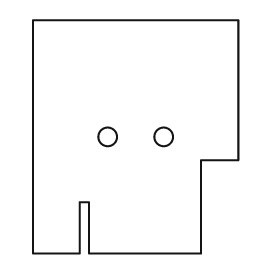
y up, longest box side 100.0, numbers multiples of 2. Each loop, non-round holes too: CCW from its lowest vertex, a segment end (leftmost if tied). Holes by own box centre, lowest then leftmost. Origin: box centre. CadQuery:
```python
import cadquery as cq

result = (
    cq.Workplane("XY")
    .moveTo(-44.0, -50.0)
    .lineTo(-24.0, -50.0)
    .lineTo(-24.0, -28.0)
    .lineTo(-20.0, -28.0)
    .lineTo(-20.0, -50.0)
    .lineTo(28.0, -50.0)
    .lineTo(28.0, -10.0)
    .lineTo(44.0, -10.0)
    .lineTo(44.0, 50.0)
    .lineTo(-44.0, 50.0)
    .close()
    .moveTo(-12.0, 0.0)
    .circle(4.0)
    .moveTo(12.0, 0.0)
    .circle(4.0)
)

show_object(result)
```